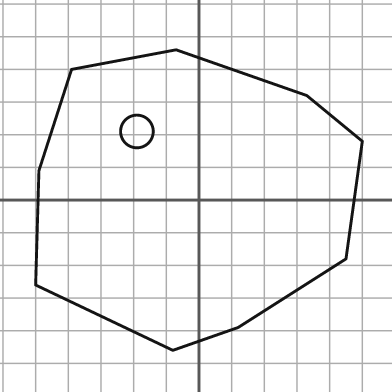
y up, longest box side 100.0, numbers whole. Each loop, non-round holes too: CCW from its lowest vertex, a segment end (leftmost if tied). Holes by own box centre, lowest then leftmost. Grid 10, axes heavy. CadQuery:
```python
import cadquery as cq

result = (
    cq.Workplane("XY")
    .moveTo(-8.0, -46.0)
    .lineTo(12.0, -39.0)
    .lineTo(45.0, -18.0)
    .lineTo(50.0, 18.0)
    .lineTo(33.0, 32.0)
    .lineTo(-7.0, 46.0)
    .lineTo(-39.0, 40.0)
    .lineTo(-49.0, 9.0)
    .lineTo(-50.0, -26.0)
    .close()
    .moveTo(-19.0, 21.0)
    .circle(5.0)
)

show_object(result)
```